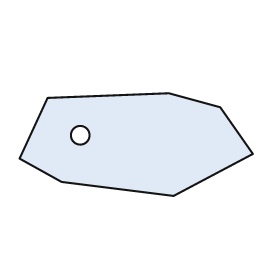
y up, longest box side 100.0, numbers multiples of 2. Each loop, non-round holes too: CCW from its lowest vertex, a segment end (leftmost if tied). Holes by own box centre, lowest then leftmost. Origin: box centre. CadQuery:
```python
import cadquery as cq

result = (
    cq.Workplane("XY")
    .moveTo(16.0, -22.0)
    .lineTo(50.0, -4.0)
    .lineTo(36.0, 16.0)
    .lineTo(14.0, 22.0)
    .lineTo(-38.0, 20.0)
    .lineTo(-50.0, -6.0)
    .lineTo(-32.0, -16.0)
    .close()
    .moveTo(-24.0, 4.0)
    .circle(4.0)
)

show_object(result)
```